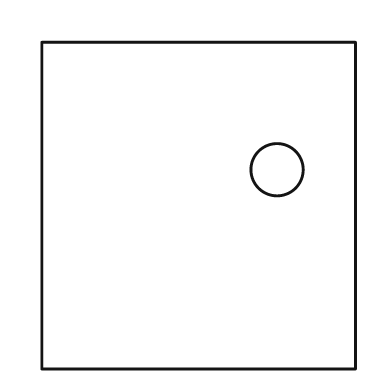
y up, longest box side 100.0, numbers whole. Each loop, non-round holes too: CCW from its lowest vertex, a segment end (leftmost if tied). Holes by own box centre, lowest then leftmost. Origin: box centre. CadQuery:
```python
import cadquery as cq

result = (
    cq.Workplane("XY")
    .moveTo(-48.0, -50.0)
    .lineTo(48.0, -50.0)
    .lineTo(48.0, 50.0)
    .lineTo(-48.0, 50.0)
    .close()
    .moveTo(24.0, 11.0)
    .circle(8.0)
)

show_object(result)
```